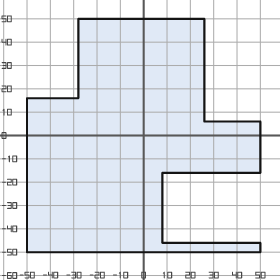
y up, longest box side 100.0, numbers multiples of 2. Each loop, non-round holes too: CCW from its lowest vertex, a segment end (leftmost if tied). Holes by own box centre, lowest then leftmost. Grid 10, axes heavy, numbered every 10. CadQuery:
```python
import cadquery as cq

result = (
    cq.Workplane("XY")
    .moveTo(-50.0, -50.0)
    .lineTo(50.0, -50.0)
    .lineTo(50.0, -46.0)
    .lineTo(8.0, -46.0)
    .lineTo(8.0, -16.0)
    .lineTo(50.0, -16.0)
    .lineTo(50.0, 6.0)
    .lineTo(26.0, 6.0)
    .lineTo(26.0, 50.0)
    .lineTo(-28.0, 50.0)
    .lineTo(-28.0, 16.0)
    .lineTo(-50.0, 16.0)
    .close()
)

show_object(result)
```